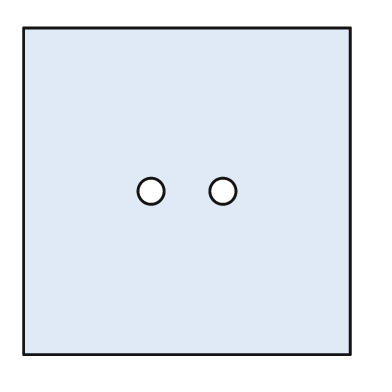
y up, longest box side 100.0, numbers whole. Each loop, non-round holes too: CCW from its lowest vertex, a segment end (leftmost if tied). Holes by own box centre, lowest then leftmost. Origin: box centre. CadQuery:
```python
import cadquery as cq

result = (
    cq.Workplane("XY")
    .moveTo(-50.0, -50.0)
    .lineTo(50.0, -50.0)
    .lineTo(50.0, 50.0)
    .lineTo(-50.0, 50.0)
    .close()
    .moveTo(-11.0, 0.0)
    .circle(4.0)
    .moveTo(11.0, 0.0)
    .circle(4.0)
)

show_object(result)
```